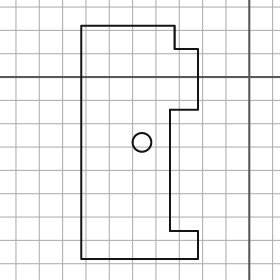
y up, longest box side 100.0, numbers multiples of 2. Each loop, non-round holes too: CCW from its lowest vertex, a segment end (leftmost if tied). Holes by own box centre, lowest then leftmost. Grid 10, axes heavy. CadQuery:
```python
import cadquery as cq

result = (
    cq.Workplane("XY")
    .moveTo(-72.0, -78.0)
    .lineTo(-22.0, -78.0)
    .lineTo(-22.0, -66.0)
    .lineTo(-34.0, -66.0)
    .lineTo(-34.0, -14.0)
    .lineTo(-22.0, -14.0)
    .lineTo(-22.0, 12.0)
    .lineTo(-32.0, 12.0)
    .lineTo(-32.0, 22.0)
    .lineTo(-72.0, 22.0)
    .close()
    .moveTo(-46.0, -28.0)
    .circle(4.0)
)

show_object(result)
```